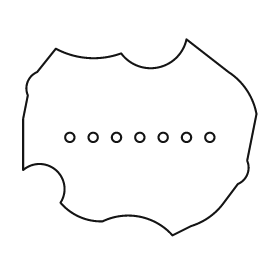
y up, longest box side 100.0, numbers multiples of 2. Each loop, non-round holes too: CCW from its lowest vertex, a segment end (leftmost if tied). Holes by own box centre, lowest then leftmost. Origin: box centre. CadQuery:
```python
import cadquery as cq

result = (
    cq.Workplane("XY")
    .moveTo(14.0, -42.0)
    .lineTo(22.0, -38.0)
    .threePointArc((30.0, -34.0), (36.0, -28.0))
    .lineTo(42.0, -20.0)
    .threePointArc((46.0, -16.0), (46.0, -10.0))
    .lineTo(50.0, 10.0)
    .threePointArc((46.0, 20.0), (38.0, 28.0))
    .lineTo(20.0, 42.0)
    .threePointArc((8.0, 30.0), (-8.0, 36.0))
    .threePointArc((-22.0, 34.0), (-36.0, 38.0))
    .lineTo(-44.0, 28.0)
    .threePointArc((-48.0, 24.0), (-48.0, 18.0))
    .lineTo(-50.0, 8.0)
    .lineTo(-50.0, -14.0)
    .threePointArc((-36.0, -14.0), (-34.0, -28.0))
    .threePointArc((-26.0, -34.0), (-16.0, -36.0))
    .threePointArc((0.0, -34.0), (14.0, -42.0))
    .close()
    .moveTo(-30.0, 0.0)
    .circle(2.0)
    .moveTo(-20.0, 0.0)
    .circle(2.0)
    .moveTo(-10.0, 0.0)
    .circle(2.0)
    .moveTo(0.0, 0.0)
    .circle(2.0)
    .moveTo(10.0, 0.0)
    .circle(2.0)
    .moveTo(20.0, 0.0)
    .circle(2.0)
    .moveTo(30.0, 0.0)
    .circle(2.0)
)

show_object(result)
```